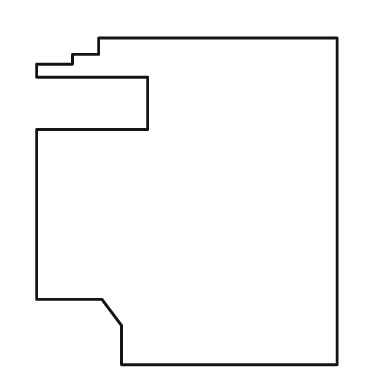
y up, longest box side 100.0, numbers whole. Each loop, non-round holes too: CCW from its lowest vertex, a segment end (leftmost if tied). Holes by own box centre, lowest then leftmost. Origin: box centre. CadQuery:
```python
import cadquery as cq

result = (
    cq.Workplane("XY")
    .moveTo(-20.0, -50.0)
    .lineTo(46.0, -50.0)
    .lineTo(46.0, 50.0)
    .lineTo(-27.0, 50.0)
    .lineTo(-27.0, 45.0)
    .lineTo(-35.0, 45.0)
    .lineTo(-35.0, 42.0)
    .lineTo(-46.0, 42.0)
    .lineTo(-46.0, 38.0)
    .lineTo(-12.0, 38.0)
    .lineTo(-12.0, 22.0)
    .lineTo(-46.0, 22.0)
    .lineTo(-46.0, -30.0)
    .lineTo(-26.0, -30.0)
    .lineTo(-20.0, -38.0)
    .close()
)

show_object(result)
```